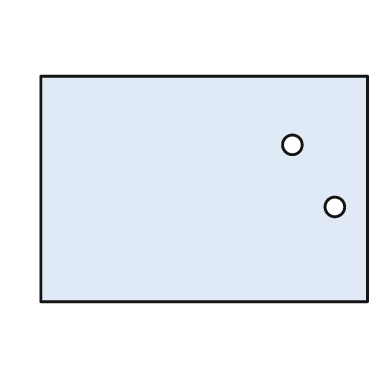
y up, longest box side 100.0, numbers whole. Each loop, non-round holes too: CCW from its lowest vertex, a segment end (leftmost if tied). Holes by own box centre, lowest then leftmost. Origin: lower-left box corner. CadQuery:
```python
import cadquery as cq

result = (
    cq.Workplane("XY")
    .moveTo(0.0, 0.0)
    .lineTo(100.0, 0.0)
    .lineTo(100.0, 69.0)
    .lineTo(0.0, 69.0)
    .close()
    .moveTo(90.0, 29.0)
    .circle(3.0)
    .moveTo(77.0, 48.0)
    .circle(3.0)
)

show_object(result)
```